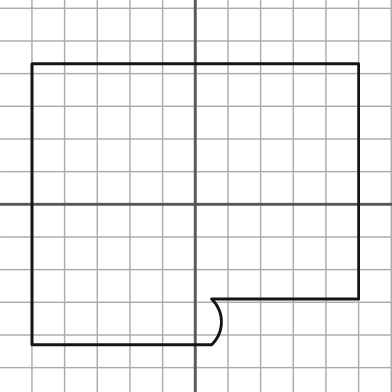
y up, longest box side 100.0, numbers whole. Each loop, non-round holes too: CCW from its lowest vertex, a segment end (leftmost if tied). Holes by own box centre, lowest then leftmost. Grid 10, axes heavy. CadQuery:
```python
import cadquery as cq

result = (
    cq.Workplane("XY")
    .moveTo(-50.0, -43.0)
    .lineTo(5.0, -43.0)
    .threePointArc((8.0, -36.0), (5.0, -29.0))
    .lineTo(50.0, -29.0)
    .lineTo(50.0, 43.0)
    .lineTo(-50.0, 43.0)
    .close()
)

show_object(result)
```